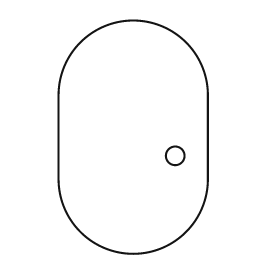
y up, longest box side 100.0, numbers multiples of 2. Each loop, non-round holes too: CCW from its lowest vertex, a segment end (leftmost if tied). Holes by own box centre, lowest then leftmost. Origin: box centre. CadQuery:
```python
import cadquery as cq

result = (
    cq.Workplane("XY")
    .moveTo(-32.0, -18.0)
    .threePointArc((0.0, -50.0), (32.0, -18.0))
    .lineTo(32.0, 18.0)
    .threePointArc((0.0, 50.0), (-32.0, 18.0))
    .close()
    .moveTo(18.0, -8.0)
    .circle(4.0)
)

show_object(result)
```